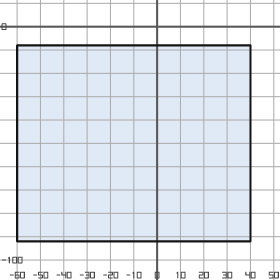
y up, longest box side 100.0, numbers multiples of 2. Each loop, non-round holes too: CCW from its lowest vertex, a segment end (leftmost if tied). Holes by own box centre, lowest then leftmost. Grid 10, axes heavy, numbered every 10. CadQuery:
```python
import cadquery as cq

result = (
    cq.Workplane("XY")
    .moveTo(-60.0, -92.0)
    .lineTo(40.0, -92.0)
    .lineTo(40.0, -8.0)
    .lineTo(-60.0, -8.0)
    .close()
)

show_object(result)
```